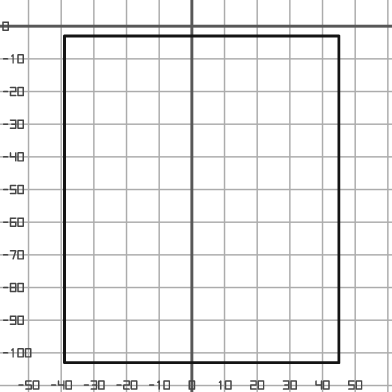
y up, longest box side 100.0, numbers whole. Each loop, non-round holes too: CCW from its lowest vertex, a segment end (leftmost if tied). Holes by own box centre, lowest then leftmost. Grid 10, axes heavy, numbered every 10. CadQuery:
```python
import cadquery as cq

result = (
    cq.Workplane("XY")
    .moveTo(-39.0, -103.0)
    .lineTo(45.0, -103.0)
    .lineTo(45.0, -3.0)
    .lineTo(-39.0, -3.0)
    .close()
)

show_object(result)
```